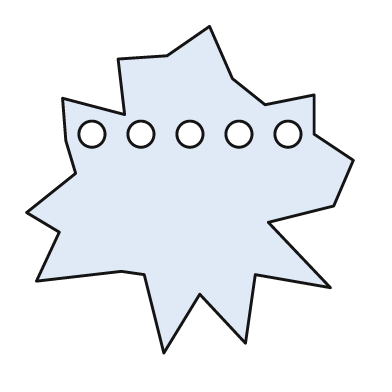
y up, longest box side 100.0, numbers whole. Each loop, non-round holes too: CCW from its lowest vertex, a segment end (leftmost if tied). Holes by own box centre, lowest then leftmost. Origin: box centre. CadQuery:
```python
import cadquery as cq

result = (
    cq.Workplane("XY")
    .moveTo(-8.0, -50.0)
    .lineTo(3.0, -32.0)
    .lineTo(17.0, -47.0)
    .lineTo(20.0, -26.0)
    .lineTo(43.0, -30.0)
    .lineTo(24.0, -10.0)
    .lineTo(44.0, -5.0)
    .lineTo(50.0, 9.0)
    .lineTo(38.0, 17.0)
    .lineTo(38.0, 29.0)
    .lineTo(23.0, 26.0)
    .lineTo(13.0, 34.0)
    .lineTo(6.0, 50.0)
    .lineTo(-7.0, 41.0)
    .lineTo(-22.0, 40.0)
    .lineTo(-20.0, 23.0)
    .lineTo(-39.0, 28.0)
    .lineTo(-38.0, 15.0)
    .lineTo(-35.0, 5.0)
    .lineTo(-50.0, -7.0)
    .lineTo(-40.0, -13.0)
    .lineTo(-47.0, -28.0)
    .lineTo(-21.0, -25.0)
    .lineTo(-14.0, -26.0)
    .close()
    .moveTo(-30.0, 17.0)
    .circle(4.0)
    .moveTo(-15.0, 17.0)
    .circle(4.0)
    .moveTo(0.0, 17.0)
    .circle(4.0)
    .moveTo(15.0, 17.0)
    .circle(4.0)
    .moveTo(30.0, 17.0)
    .circle(4.0)
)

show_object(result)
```